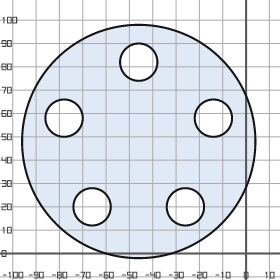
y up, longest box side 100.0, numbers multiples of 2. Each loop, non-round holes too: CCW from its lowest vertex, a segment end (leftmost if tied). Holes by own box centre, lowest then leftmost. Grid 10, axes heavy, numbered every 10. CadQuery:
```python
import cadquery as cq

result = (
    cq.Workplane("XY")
    .moveTo(-46.0, 48.0)
    .circle(50.0)
    .moveTo(-66.0, 20.0)
    .circle(8.0)
    .moveTo(-26.0, 20.0)
    .circle(8.0)
    .moveTo(-78.0, 58.0)
    .circle(8.0)
    .moveTo(-14.0, 58.0)
    .circle(8.0)
    .moveTo(-46.0, 82.0)
    .circle(8.0)
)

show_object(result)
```